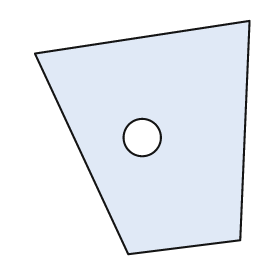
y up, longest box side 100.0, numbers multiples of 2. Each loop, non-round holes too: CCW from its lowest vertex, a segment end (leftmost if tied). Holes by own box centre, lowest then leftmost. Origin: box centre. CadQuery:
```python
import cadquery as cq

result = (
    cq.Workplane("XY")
    .moveTo(-6.0, -50.0)
    .lineTo(42.0, -44.0)
    .lineTo(46.0, 50.0)
    .lineTo(-46.0, 36.0)
    .close()
    .moveTo(0.0, 0.0)
    .circle(8.0)
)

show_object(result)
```